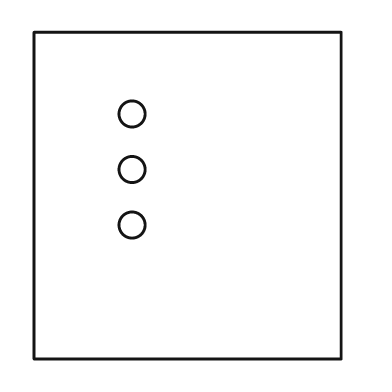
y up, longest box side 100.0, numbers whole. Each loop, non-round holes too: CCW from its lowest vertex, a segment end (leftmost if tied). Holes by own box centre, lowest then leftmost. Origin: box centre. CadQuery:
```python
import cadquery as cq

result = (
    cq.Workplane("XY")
    .moveTo(-47.0, -50.0)
    .lineTo(47.0, -50.0)
    .lineTo(47.0, 50.0)
    .lineTo(-47.0, 50.0)
    .close()
    .moveTo(-17.0, -9.0)
    .circle(4.0)
    .moveTo(-17.0, 8.0)
    .circle(4.0)
    .moveTo(-17.0, 25.0)
    .circle(4.0)
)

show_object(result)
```